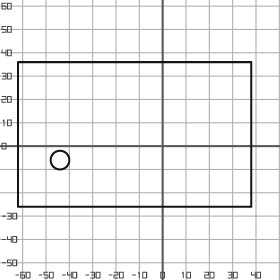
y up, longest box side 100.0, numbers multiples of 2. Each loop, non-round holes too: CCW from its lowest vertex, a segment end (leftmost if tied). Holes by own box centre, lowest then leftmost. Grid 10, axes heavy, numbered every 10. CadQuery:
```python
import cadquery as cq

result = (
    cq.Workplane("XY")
    .moveTo(-62.0, -26.0)
    .lineTo(38.0, -26.0)
    .lineTo(38.0, 36.0)
    .lineTo(-62.0, 36.0)
    .close()
    .moveTo(-44.0, -6.0)
    .circle(4.0)
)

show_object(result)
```